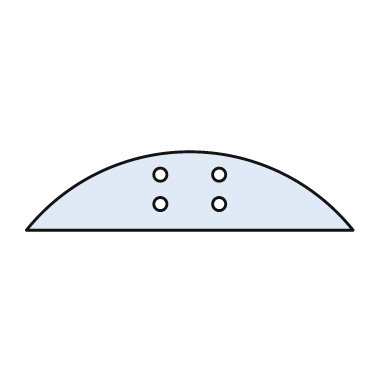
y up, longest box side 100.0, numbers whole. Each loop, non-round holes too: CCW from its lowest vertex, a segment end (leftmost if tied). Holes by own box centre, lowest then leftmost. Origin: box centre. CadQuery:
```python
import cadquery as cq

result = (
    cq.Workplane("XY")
    .moveTo(-50.0, -12.0)
    .lineTo(50.0, -12.0)
    .threePointArc((0.0, 12.0), (-50.0, -12.0))
    .close()
    .moveTo(-9.0, -4.0)
    .circle(2.0)
    .moveTo(9.0, -4.0)
    .circle(2.0)
    .moveTo(-9.0, 5.0)
    .circle(2.0)
    .moveTo(9.0, 5.0)
    .circle(2.0)
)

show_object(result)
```